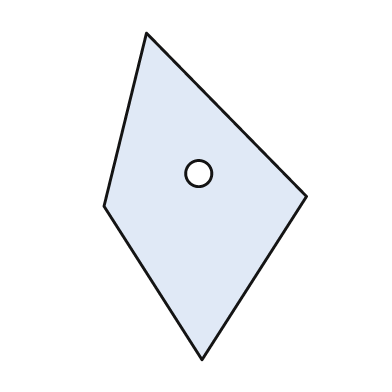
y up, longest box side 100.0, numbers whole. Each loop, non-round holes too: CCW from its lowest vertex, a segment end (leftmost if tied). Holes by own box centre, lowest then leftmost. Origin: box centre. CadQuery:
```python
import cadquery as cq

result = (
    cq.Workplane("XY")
    .moveTo(-1.0, -50.0)
    .lineTo(31.0, 0.0)
    .lineTo(-18.0, 50.0)
    .lineTo(-31.0, -3.0)
    .close()
    .moveTo(-2.0, 7.0)
    .circle(4.0)
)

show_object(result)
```